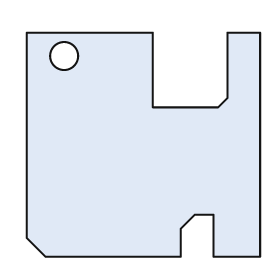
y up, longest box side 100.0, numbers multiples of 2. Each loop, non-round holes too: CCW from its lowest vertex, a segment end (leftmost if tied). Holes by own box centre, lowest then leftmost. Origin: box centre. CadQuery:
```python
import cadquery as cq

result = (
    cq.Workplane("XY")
    .moveTo(-42.0, -48.0)
    .lineTo(16.0, -48.0)
    .lineTo(16.0, -36.0)
    .lineTo(22.0, -30.0)
    .lineTo(30.0, -30.0)
    .lineTo(30.0, -48.0)
    .lineTo(50.0, -48.0)
    .lineTo(50.0, 48.0)
    .lineTo(36.0, 48.0)
    .lineTo(36.0, 20.0)
    .lineTo(32.0, 16.0)
    .lineTo(4.0, 16.0)
    .lineTo(4.0, 48.0)
    .lineTo(-50.0, 48.0)
    .lineTo(-50.0, -40.0)
    .close()
    .moveTo(-34.0, 38.0)
    .circle(6.0)
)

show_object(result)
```